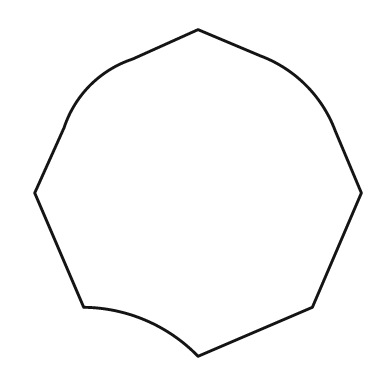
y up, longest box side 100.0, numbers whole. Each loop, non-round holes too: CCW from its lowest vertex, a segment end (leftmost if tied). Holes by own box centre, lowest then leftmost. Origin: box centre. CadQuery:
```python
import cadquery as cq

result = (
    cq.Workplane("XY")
    .moveTo(0.0, -50.0)
    .lineTo(35.0, -35.0)
    .lineTo(50.0, 0.0)
    .lineTo(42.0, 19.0)
    .threePointArc((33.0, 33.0), (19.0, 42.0))
    .lineTo(0.0, 50.0)
    .lineTo(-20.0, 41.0)
    .threePointArc((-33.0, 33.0), (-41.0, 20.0))
    .lineTo(-50.0, 0.0)
    .lineTo(-35.0, -35.0)
    .threePointArc((-16.0, -39.0), (0.0, -50.0))
    .close()
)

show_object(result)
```